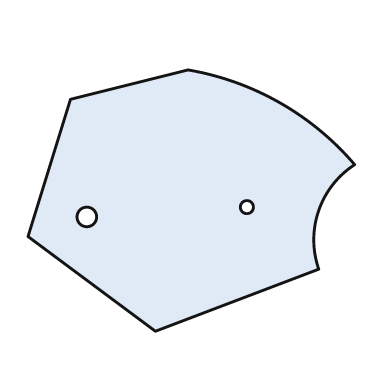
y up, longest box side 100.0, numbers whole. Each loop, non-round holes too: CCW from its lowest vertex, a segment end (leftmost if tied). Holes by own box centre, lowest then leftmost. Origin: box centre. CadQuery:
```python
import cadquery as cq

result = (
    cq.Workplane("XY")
    .moveTo(-11.0, -40.0)
    .lineTo(39.0, -21.0)
    .threePointArc((39.0, -3.0), (50.0, 11.0))
    .threePointArc((27.0, 30.0), (-1.0, 40.0))
    .lineTo(-37.0, 31.0)
    .lineTo(-50.0, -11.0)
    .close()
    .moveTo(-32.0, -5.0)
    .circle(3.0)
    .moveTo(17.0, -2.0)
    .circle(2.0)
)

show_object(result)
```